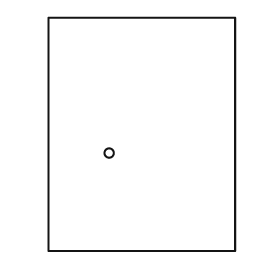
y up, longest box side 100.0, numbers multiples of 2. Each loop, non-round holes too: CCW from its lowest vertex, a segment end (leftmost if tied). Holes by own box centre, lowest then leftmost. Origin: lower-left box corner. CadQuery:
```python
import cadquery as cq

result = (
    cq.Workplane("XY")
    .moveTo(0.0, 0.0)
    .lineTo(80.0, 0.0)
    .lineTo(80.0, 100.0)
    .lineTo(0.0, 100.0)
    .close()
    .moveTo(26.0, 42.0)
    .circle(2.0)
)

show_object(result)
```